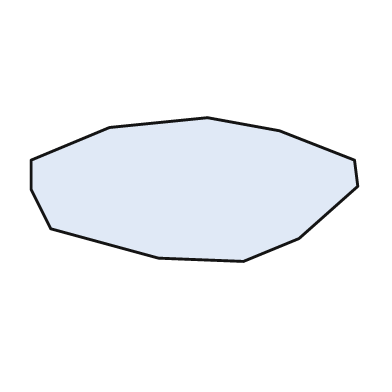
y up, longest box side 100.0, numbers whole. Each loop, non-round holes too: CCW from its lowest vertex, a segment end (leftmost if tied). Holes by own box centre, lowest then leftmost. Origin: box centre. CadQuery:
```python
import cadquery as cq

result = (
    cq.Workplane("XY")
    .moveTo(15.0, -22.0)
    .lineTo(32.0, -15.0)
    .lineTo(50.0, 1.0)
    .lineTo(49.0, 9.0)
    .lineTo(26.0, 18.0)
    .lineTo(4.0, 22.0)
    .lineTo(-26.0, 19.0)
    .lineTo(-50.0, 9.0)
    .lineTo(-50.0, 0.0)
    .lineTo(-44.0, -12.0)
    .lineTo(-11.0, -21.0)
    .close()
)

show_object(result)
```